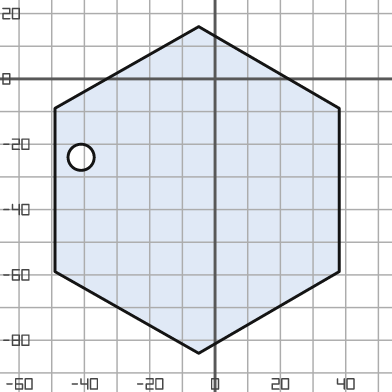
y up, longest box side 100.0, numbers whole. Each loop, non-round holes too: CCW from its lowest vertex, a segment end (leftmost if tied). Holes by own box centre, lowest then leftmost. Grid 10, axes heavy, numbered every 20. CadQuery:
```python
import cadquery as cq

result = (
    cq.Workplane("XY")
    .moveTo(-5.0, -84.0)
    .lineTo(38.0, -59.0)
    .lineTo(38.0, -9.0)
    .lineTo(-5.0, 16.0)
    .lineTo(-49.0, -9.0)
    .lineTo(-49.0, -59.0)
    .close()
    .moveTo(-41.0, -24.0)
    .circle(4.0)
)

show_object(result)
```